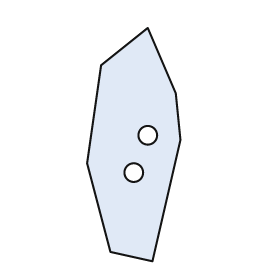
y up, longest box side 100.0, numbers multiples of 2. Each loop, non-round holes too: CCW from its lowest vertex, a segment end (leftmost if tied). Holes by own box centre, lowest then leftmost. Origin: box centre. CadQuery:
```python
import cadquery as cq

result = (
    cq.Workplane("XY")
    .moveTo(8.0, -50.0)
    .lineTo(20.0, 2.0)
    .lineTo(18.0, 22.0)
    .lineTo(6.0, 50.0)
    .lineTo(-14.0, 34.0)
    .lineTo(-20.0, -8.0)
    .lineTo(-10.0, -46.0)
    .close()
    .moveTo(0.0, -12.0)
    .circle(4.0)
    .moveTo(6.0, 4.0)
    .circle(4.0)
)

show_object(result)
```